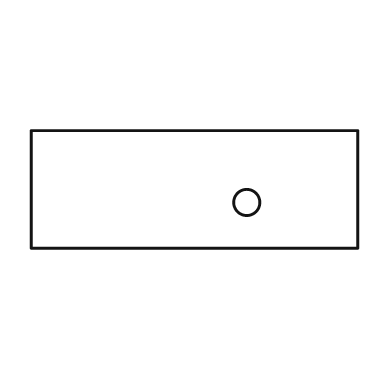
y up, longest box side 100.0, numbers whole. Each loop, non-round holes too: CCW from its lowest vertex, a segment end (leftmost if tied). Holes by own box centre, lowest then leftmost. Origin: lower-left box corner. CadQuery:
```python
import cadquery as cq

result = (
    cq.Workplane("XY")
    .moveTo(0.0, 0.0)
    .lineTo(100.0, 0.0)
    .lineTo(100.0, 36.0)
    .lineTo(0.0, 36.0)
    .close()
    .moveTo(66.0, 14.0)
    .circle(4.0)
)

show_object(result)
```